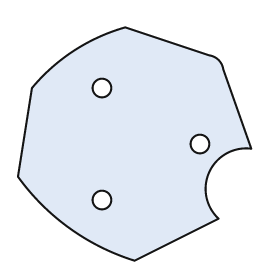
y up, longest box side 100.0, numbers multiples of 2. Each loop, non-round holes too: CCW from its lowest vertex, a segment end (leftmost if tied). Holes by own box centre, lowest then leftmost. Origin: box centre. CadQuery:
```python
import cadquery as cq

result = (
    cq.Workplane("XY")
    .moveTo(0.0, -50.0)
    .lineTo(36.0, -32.0)
    .threePointArc((32.0, -12.0), (50.0, -2.0))
    .lineTo(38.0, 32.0)
    .threePointArc((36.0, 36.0), (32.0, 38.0))
    .lineTo(-4.0, 50.0)
    .threePointArc((-26.0, 40.0), (-44.0, 24.0))
    .lineTo(-50.0, -14.0)
    .threePointArc((-28.0, -36.0), (0.0, -50.0))
    .close()
    .moveTo(-14.0, -24.0)
    .circle(4.0)
    .moveTo(28.0, 0.0)
    .circle(4.0)
    .moveTo(-14.0, 24.0)
    .circle(4.0)
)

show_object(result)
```